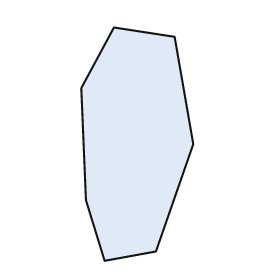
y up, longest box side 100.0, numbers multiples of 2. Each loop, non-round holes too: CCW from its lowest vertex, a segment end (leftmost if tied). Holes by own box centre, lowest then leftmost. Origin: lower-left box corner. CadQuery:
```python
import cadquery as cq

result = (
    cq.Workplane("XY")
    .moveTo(10.0, 0.0)
    .lineTo(32.0, 4.0)
    .lineTo(48.0, 50.0)
    .lineTo(40.0, 96.0)
    .lineTo(14.0, 100.0)
    .lineTo(0.0, 74.0)
    .lineTo(2.0, 26.0)
    .close()
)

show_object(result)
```